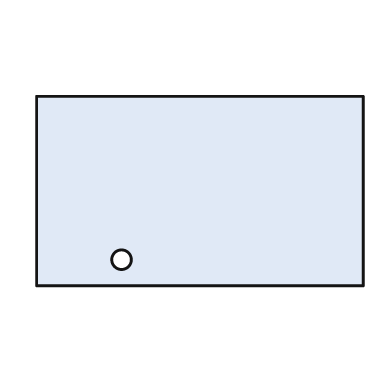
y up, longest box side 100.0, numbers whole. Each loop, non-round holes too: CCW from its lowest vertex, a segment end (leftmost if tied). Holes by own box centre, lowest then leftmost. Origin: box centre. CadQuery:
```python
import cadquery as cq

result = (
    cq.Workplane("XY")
    .moveTo(-50.0, -29.0)
    .lineTo(50.0, -29.0)
    .lineTo(50.0, 29.0)
    .lineTo(-50.0, 29.0)
    .close()
    .moveTo(-24.0, -21.0)
    .circle(3.0)
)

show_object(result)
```